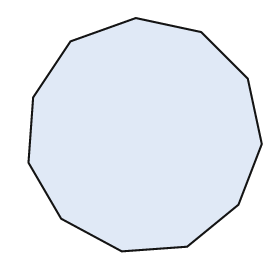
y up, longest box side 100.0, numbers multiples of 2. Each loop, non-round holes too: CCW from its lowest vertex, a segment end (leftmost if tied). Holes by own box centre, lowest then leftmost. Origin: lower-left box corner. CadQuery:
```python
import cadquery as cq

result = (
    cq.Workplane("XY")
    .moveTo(40.0, 0.0)
    .lineTo(68.0, 2.0)
    .lineTo(90.0, 20.0)
    .lineTo(100.0, 46.0)
    .lineTo(94.0, 74.0)
    .lineTo(74.0, 94.0)
    .lineTo(46.0, 100.0)
    .lineTo(18.0, 90.0)
    .lineTo(2.0, 66.0)
    .lineTo(0.0, 38.0)
    .lineTo(14.0, 14.0)
    .close()
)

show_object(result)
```